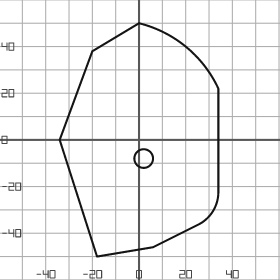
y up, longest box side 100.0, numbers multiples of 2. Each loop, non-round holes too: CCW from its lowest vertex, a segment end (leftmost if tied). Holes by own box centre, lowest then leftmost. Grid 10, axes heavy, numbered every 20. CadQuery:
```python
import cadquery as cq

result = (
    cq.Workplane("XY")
    .moveTo(-18.0, -50.0)
    .lineTo(6.0, -46.0)
    .lineTo(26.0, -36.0)
    .threePointArc((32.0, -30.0), (34.0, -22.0))
    .lineTo(34.0, 22.0)
    .threePointArc((20.0, 40.0), (0.0, 50.0))
    .lineTo(-20.0, 38.0)
    .lineTo(-34.0, 0.0)
    .close()
    .moveTo(2.0, -8.0)
    .circle(4.0)
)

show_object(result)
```